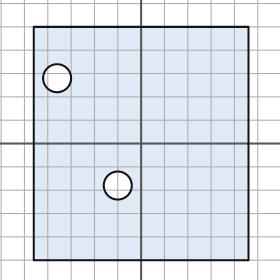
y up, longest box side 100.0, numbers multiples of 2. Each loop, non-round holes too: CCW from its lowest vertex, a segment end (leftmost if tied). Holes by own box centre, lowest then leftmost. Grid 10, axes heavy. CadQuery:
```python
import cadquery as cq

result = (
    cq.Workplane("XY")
    .moveTo(-46.0, -50.0)
    .lineTo(46.0, -50.0)
    .lineTo(46.0, 50.0)
    .lineTo(-46.0, 50.0)
    .close()
    .moveTo(-10.0, -18.0)
    .circle(6.0)
    .moveTo(-36.0, 28.0)
    .circle(6.0)
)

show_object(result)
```